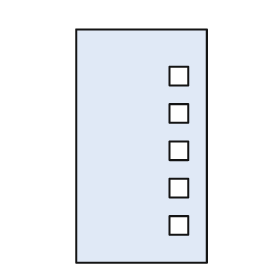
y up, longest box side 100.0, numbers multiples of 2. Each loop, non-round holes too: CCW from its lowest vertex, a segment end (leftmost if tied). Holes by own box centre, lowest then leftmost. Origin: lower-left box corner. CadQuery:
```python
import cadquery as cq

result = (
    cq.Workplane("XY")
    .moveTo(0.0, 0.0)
    .lineTo(56.0, 0.0)
    .lineTo(56.0, 100.0)
    .lineTo(0.0, 100.0)
    .close()
    .moveTo(40.0, 12.0)
    .lineTo(48.0, 12.0)
    .lineTo(48.0, 20.0)
    .lineTo(40.0, 20.0)
    .close()
    .moveTo(40.0, 28.0)
    .lineTo(48.0, 28.0)
    .lineTo(48.0, 36.0)
    .lineTo(40.0, 36.0)
    .close()
    .moveTo(40.0, 44.0)
    .lineTo(48.0, 44.0)
    .lineTo(48.0, 52.0)
    .lineTo(40.0, 52.0)
    .close()
    .moveTo(40.0, 60.0)
    .lineTo(48.0, 60.0)
    .lineTo(48.0, 68.0)
    .lineTo(40.0, 68.0)
    .close()
    .moveTo(40.0, 76.0)
    .lineTo(48.0, 76.0)
    .lineTo(48.0, 84.0)
    .lineTo(40.0, 84.0)
    .close()
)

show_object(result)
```